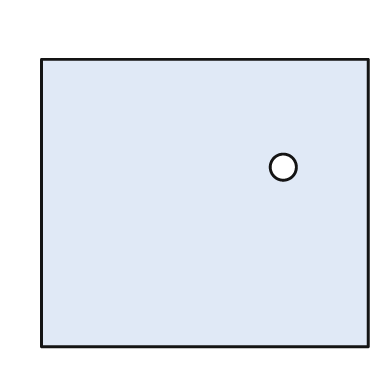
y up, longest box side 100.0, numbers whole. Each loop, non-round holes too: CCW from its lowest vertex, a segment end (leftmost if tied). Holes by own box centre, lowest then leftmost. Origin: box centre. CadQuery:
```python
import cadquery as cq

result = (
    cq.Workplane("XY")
    .moveTo(-50.0, -44.0)
    .lineTo(50.0, -44.0)
    .lineTo(50.0, 44.0)
    .lineTo(-50.0, 44.0)
    .close()
    .moveTo(24.0, 11.0)
    .circle(4.0)
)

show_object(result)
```